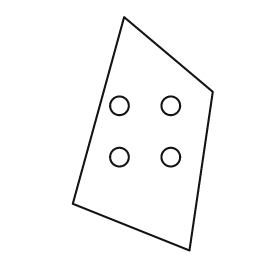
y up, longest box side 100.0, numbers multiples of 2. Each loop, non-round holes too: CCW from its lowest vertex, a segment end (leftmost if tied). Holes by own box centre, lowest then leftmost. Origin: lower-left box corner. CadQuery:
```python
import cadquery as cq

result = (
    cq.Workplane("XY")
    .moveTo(50.0, 0.0)
    .lineTo(60.0, 68.0)
    .lineTo(22.0, 100.0)
    .lineTo(0.0, 20.0)
    .close()
    .moveTo(20.0, 40.0)
    .circle(4.0)
    .moveTo(42.0, 40.0)
    .circle(4.0)
    .moveTo(20.0, 62.0)
    .circle(4.0)
    .moveTo(42.0, 62.0)
    .circle(4.0)
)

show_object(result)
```